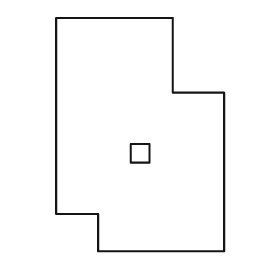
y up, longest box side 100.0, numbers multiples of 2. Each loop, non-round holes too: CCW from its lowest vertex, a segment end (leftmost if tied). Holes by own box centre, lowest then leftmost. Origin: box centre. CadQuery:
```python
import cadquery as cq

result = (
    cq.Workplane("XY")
    .moveTo(-18.0, -50.0)
    .lineTo(36.0, -50.0)
    .lineTo(36.0, 18.0)
    .lineTo(14.0, 18.0)
    .lineTo(14.0, 50.0)
    .lineTo(-36.0, 50.0)
    .lineTo(-36.0, -34.0)
    .lineTo(-18.0, -34.0)
    .close()
    .moveTo(-4.0, -12.0)
    .lineTo(4.0, -12.0)
    .lineTo(4.0, -4.0)
    .lineTo(-4.0, -4.0)
    .close()
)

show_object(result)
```